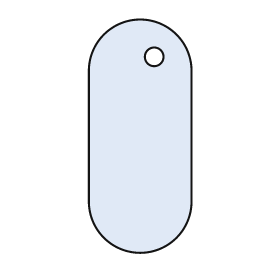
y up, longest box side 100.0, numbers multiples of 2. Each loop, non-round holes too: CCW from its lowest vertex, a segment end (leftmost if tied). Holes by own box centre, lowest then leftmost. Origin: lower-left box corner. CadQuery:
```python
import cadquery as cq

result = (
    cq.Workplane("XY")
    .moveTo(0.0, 22.0)
    .threePointArc((22.0, 0.0), (44.0, 22.0))
    .lineTo(44.0, 78.0)
    .threePointArc((22.0, 100.0), (0.0, 78.0))
    .close()
    .moveTo(28.0, 84.0)
    .circle(4.0)
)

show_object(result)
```